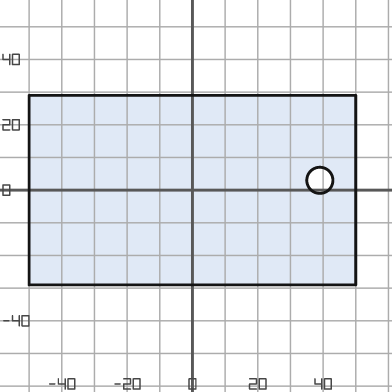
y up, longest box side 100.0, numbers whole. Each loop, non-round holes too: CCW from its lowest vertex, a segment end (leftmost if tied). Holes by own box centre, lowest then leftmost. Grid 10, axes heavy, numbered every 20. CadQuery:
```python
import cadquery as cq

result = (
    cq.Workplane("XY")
    .moveTo(-50.0, -29.0)
    .lineTo(50.0, -29.0)
    .lineTo(50.0, 29.0)
    .lineTo(-50.0, 29.0)
    .close()
    .moveTo(39.0, 3.0)
    .circle(4.0)
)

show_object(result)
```